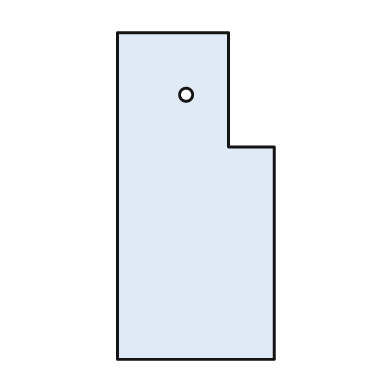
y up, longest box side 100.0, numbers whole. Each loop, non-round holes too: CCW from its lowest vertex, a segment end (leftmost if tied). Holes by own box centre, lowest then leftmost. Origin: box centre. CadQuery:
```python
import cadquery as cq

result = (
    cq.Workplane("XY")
    .moveTo(-24.0, -50.0)
    .lineTo(24.0, -50.0)
    .lineTo(24.0, 15.0)
    .lineTo(10.0, 15.0)
    .lineTo(10.0, 50.0)
    .lineTo(-24.0, 50.0)
    .close()
    .moveTo(-3.0, 31.0)
    .circle(2.0)
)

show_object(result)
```